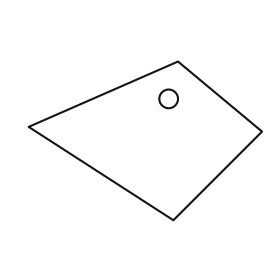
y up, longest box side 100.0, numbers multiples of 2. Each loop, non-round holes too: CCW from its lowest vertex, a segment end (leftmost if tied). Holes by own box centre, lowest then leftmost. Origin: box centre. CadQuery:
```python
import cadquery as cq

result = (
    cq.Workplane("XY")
    .moveTo(12.0, -34.0)
    .lineTo(50.0, 4.0)
    .lineTo(14.0, 34.0)
    .lineTo(-50.0, 6.0)
    .close()
    .moveTo(10.0, 18.0)
    .circle(4.0)
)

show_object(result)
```